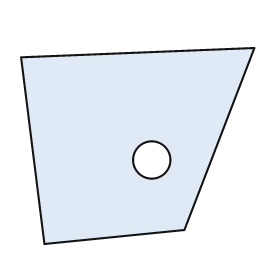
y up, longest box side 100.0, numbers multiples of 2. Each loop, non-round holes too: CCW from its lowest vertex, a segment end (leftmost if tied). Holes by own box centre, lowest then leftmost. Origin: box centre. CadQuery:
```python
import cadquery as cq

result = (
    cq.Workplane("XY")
    .moveTo(-40.0, -42.0)
    .lineTo(20.0, -36.0)
    .lineTo(50.0, 42.0)
    .lineTo(-50.0, 38.0)
    .close()
    .moveTo(6.0, -6.0)
    .circle(8.0)
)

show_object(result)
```